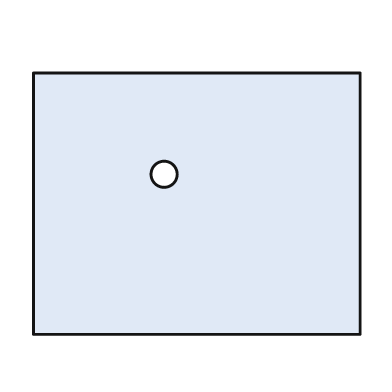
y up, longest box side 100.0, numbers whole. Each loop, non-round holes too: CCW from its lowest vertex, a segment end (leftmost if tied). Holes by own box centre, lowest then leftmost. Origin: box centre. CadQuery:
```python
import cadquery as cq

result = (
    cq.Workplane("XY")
    .moveTo(-50.0, -40.0)
    .lineTo(50.0, -40.0)
    .lineTo(50.0, 40.0)
    .lineTo(-50.0, 40.0)
    .close()
    .moveTo(-10.0, 9.0)
    .circle(4.0)
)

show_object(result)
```